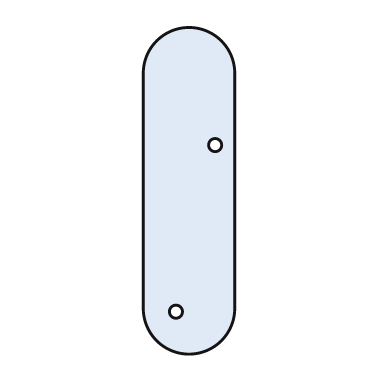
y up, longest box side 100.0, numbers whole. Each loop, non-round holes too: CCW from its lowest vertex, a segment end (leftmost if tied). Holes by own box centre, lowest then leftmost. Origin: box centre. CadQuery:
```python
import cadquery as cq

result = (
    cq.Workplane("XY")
    .moveTo(-14.0, -36.0)
    .threePointArc((0.0, -50.0), (14.0, -36.0))
    .lineTo(14.0, 36.0)
    .threePointArc((0.0, 50.0), (-14.0, 36.0))
    .close()
    .moveTo(-4.0, -37.0)
    .circle(2.0)
    .moveTo(8.0, 14.0)
    .circle(2.0)
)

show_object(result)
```